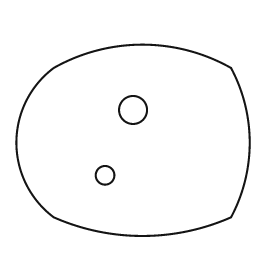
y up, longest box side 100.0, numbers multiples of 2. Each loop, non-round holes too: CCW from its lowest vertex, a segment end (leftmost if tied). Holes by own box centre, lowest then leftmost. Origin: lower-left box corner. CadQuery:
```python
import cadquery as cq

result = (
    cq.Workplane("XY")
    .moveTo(16.0, 8.0)
    .threePointArc((54.0, 0.0), (92.0, 8.0))
    .threePointArc((100.0, 40.0), (92.0, 72.0))
    .threePointArc((54.0, 82.0), (16.0, 72.0))
    .threePointArc((0.0, 40.0), (16.0, 8.0))
    .close()
    .moveTo(38.0, 26.0)
    .circle(4.0)
    .moveTo(50.0, 54.0)
    .circle(6.0)
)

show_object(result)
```